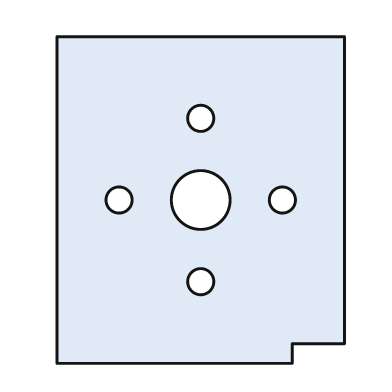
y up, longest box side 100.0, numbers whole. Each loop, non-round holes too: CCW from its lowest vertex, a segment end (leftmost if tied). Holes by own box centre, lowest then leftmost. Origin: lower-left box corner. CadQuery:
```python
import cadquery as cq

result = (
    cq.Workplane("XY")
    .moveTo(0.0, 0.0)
    .lineTo(72.0, 0.0)
    .lineTo(72.0, 6.0)
    .lineTo(88.0, 6.0)
    .lineTo(88.0, 100.0)
    .lineTo(0.0, 100.0)
    .close()
    .moveTo(44.0, 25.0)
    .circle(4.0)
    .moveTo(19.0, 50.0)
    .circle(4.0)
    .moveTo(44.0, 50.0)
    .circle(9.0)
    .moveTo(69.0, 50.0)
    .circle(4.0)
    .moveTo(44.0, 75.0)
    .circle(4.0)
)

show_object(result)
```